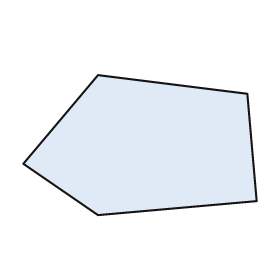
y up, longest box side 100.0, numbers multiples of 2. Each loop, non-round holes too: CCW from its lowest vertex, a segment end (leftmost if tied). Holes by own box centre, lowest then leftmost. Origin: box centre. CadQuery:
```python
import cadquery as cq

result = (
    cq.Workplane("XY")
    .moveTo(-18.0, -30.0)
    .lineTo(50.0, -24.0)
    .lineTo(46.0, 22.0)
    .lineTo(-18.0, 30.0)
    .lineTo(-50.0, -8.0)
    .close()
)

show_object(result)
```